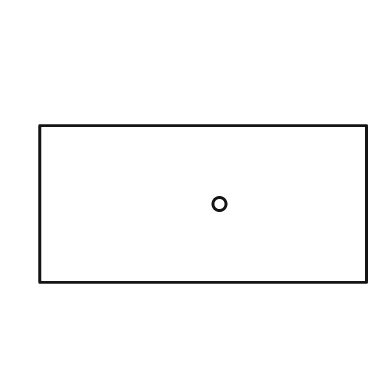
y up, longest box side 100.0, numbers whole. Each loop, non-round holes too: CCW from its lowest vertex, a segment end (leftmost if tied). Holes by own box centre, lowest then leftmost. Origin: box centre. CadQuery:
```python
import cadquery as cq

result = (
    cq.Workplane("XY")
    .moveTo(-50.0, -24.0)
    .lineTo(50.0, -24.0)
    .lineTo(50.0, 24.0)
    .lineTo(-50.0, 24.0)
    .close()
    .moveTo(5.0, 0.0)
    .circle(2.0)
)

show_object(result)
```